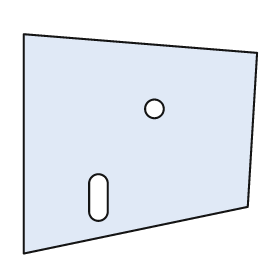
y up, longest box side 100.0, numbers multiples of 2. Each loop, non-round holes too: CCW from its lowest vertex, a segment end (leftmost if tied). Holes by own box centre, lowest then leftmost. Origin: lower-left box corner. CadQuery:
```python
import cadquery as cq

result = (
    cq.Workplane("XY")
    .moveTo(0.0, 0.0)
    .lineTo(96.0, 20.0)
    .lineTo(100.0, 86.0)
    .lineTo(0.0, 94.0)
    .close()
    .moveTo(28.0, 18.0)
    .threePointArc((32.0, 14.0), (36.0, 18.0))
    .lineTo(36.0, 30.0)
    .threePointArc((32.0, 34.0), (28.0, 30.0))
    .close()
    .moveTo(56.0, 62.0)
    .circle(4.0)
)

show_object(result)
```